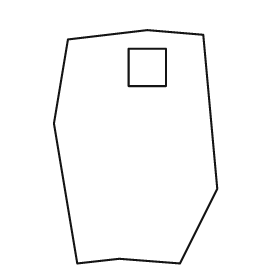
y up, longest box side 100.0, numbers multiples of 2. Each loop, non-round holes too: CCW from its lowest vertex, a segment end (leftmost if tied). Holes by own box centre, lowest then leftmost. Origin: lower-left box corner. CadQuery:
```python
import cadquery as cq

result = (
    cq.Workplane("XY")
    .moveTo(10.0, 0.0)
    .lineTo(28.0, 2.0)
    .lineTo(54.0, 0.0)
    .lineTo(70.0, 32.0)
    .lineTo(64.0, 98.0)
    .lineTo(40.0, 100.0)
    .lineTo(6.0, 96.0)
    .lineTo(0.0, 60.0)
    .close()
    .moveTo(32.0, 76.0)
    .lineTo(48.0, 76.0)
    .lineTo(48.0, 92.0)
    .lineTo(32.0, 92.0)
    .close()
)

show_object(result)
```